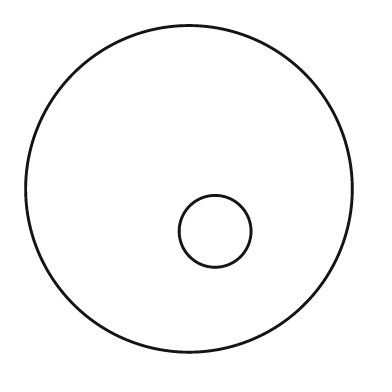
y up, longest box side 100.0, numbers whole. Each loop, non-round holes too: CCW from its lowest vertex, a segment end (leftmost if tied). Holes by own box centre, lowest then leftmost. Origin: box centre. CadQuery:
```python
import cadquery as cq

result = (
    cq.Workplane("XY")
    .moveTo(0.0, 0.0)
    .circle(50.0)
    .moveTo(8.0, -13.0)
    .circle(11.0)
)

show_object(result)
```